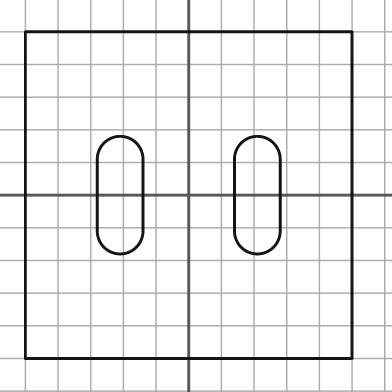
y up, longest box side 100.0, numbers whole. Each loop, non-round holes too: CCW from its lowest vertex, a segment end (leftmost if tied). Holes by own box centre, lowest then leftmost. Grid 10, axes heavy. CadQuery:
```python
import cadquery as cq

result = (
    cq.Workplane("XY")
    .moveTo(-50.0, -50.0)
    .lineTo(50.0, -50.0)
    .lineTo(50.0, 50.0)
    .lineTo(-50.0, 50.0)
    .close()
    .moveTo(-28.0, -11.0)
    .threePointArc((-21.0, -18.0), (-14.0, -11.0))
    .lineTo(-14.0, 11.0)
    .threePointArc((-21.0, 18.0), (-28.0, 11.0))
    .close()
    .moveTo(14.0, -11.0)
    .threePointArc((21.0, -18.0), (28.0, -11.0))
    .lineTo(28.0, 11.0)
    .threePointArc((21.0, 18.0), (14.0, 11.0))
    .close()
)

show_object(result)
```